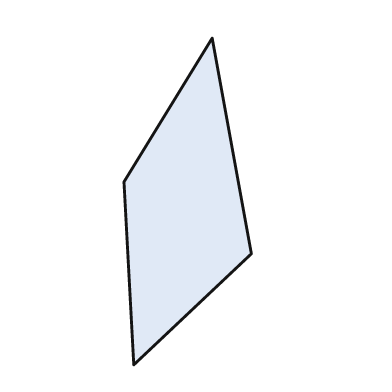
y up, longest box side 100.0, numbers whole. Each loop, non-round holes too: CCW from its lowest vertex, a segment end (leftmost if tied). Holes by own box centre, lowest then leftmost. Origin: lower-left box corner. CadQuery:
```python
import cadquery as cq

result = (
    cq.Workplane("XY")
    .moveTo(3.0, 0.0)
    .lineTo(39.0, 34.0)
    .lineTo(27.0, 100.0)
    .lineTo(0.0, 56.0)
    .close()
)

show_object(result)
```